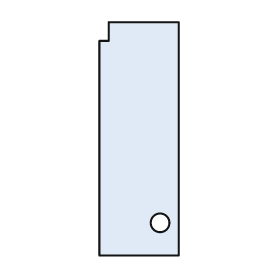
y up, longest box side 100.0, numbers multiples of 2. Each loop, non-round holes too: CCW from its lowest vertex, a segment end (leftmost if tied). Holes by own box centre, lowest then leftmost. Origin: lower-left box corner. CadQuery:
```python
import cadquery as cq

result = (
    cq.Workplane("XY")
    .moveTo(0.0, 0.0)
    .lineTo(34.0, 0.0)
    .lineTo(34.0, 100.0)
    .lineTo(4.0, 100.0)
    .lineTo(4.0, 92.0)
    .lineTo(0.0, 92.0)
    .close()
    .moveTo(26.0, 14.0)
    .circle(4.0)
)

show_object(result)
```